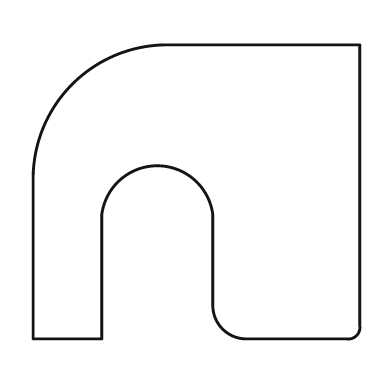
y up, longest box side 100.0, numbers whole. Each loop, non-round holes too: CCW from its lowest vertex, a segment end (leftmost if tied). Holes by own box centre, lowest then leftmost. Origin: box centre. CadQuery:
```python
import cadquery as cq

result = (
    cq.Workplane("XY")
    .moveTo(-50.0, -45.0)
    .lineTo(-29.0, -45.0)
    .lineTo(-29.0, -7.0)
    .threePointArc((-12.0, 8.0), (5.0, -7.0))
    .lineTo(5.0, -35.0)
    .threePointArc((8.0, -42.0), (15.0, -45.0))
    .lineTo(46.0, -45.0)
    .threePointArc((49.0, -44.0), (50.0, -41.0))
    .lineTo(50.0, 45.0)
    .lineTo(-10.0, 45.0)
    .threePointArc((-38.0, 33.0), (-50.0, 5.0))
    .close()
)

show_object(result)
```